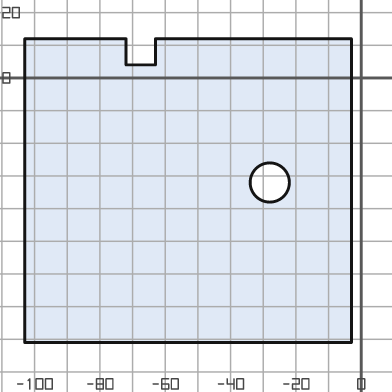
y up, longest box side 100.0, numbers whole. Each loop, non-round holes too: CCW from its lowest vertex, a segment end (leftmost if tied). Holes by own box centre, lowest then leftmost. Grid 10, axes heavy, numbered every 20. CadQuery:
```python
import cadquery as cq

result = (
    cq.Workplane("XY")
    .moveTo(-103.0, -81.0)
    .lineTo(-3.0, -81.0)
    .lineTo(-3.0, 12.0)
    .lineTo(-63.0, 12.0)
    .lineTo(-63.0, 4.0)
    .lineTo(-72.0, 4.0)
    .lineTo(-72.0, 12.0)
    .lineTo(-103.0, 12.0)
    .close()
    .moveTo(-28.0, -32.0)
    .circle(6.0)
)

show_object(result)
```